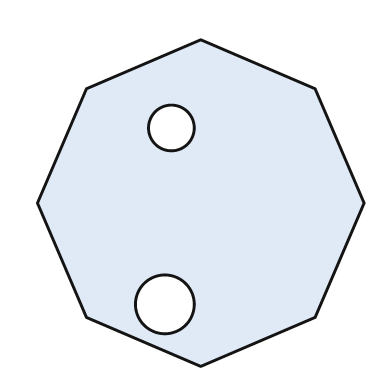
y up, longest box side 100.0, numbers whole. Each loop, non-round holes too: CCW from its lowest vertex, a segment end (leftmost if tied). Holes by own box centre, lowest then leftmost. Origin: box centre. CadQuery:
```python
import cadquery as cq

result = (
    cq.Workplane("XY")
    .moveTo(0.0, -50.0)
    .lineTo(35.0, -35.0)
    .lineTo(50.0, 0.0)
    .lineTo(35.0, 35.0)
    .lineTo(0.0, 50.0)
    .lineTo(-35.0, 35.0)
    .lineTo(-50.0, 0.0)
    .lineTo(-35.0, -35.0)
    .close()
    .moveTo(-11.0, -31.0)
    .circle(9.0)
    .moveTo(-9.0, 23.0)
    .circle(7.0)
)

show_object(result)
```